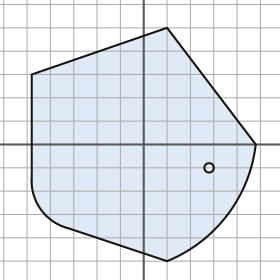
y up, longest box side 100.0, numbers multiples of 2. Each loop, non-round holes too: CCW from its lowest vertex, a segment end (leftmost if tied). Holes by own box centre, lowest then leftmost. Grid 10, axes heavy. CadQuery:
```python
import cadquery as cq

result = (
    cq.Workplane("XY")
    .moveTo(10.0, -50.0)
    .threePointArc((36.0, -30.0), (48.0, 0.0))
    .lineTo(10.0, 50.0)
    .lineTo(-48.0, 30.0)
    .lineTo(-48.0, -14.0)
    .threePointArc((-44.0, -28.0), (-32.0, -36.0))
    .close()
    .moveTo(28.0, -10.0)
    .circle(2.0)
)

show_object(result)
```